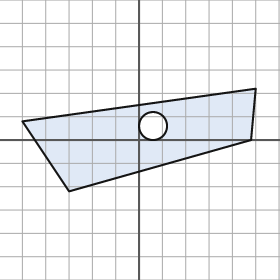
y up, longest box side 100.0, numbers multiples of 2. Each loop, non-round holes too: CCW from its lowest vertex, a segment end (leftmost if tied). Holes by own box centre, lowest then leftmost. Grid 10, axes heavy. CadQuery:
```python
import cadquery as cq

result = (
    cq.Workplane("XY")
    .moveTo(-30.0, -22.0)
    .lineTo(48.0, 0.0)
    .lineTo(50.0, 22.0)
    .lineTo(-50.0, 8.0)
    .close()
    .moveTo(6.0, 6.0)
    .circle(6.0)
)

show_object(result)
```